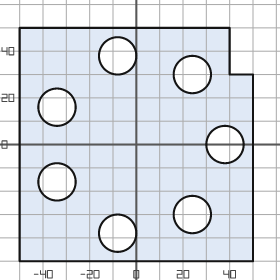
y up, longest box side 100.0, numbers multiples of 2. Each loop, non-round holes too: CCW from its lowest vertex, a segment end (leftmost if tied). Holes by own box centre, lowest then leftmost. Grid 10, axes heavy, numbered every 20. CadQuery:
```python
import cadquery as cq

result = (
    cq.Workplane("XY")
    .moveTo(-50.0, -50.0)
    .lineTo(50.0, -50.0)
    .lineTo(50.0, 30.0)
    .lineTo(40.0, 30.0)
    .lineTo(40.0, 50.0)
    .lineTo(-50.0, 50.0)
    .close()
    .moveTo(-8.0, -38.0)
    .circle(8.0)
    .moveTo(24.0, -30.0)
    .circle(8.0)
    .moveTo(-34.0, -16.0)
    .circle(8.0)
    .moveTo(38.0, 0.0)
    .circle(8.0)
    .moveTo(-34.0, 16.0)
    .circle(8.0)
    .moveTo(24.0, 30.0)
    .circle(8.0)
    .moveTo(-8.0, 38.0)
    .circle(8.0)
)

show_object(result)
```